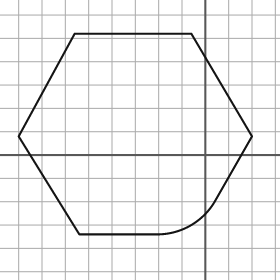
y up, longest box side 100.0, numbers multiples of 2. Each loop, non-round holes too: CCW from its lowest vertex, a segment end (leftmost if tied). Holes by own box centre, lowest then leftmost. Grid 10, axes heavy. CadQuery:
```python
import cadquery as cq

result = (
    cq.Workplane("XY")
    .moveTo(-54.0, -34.0)
    .lineTo(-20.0, -34.0)
    .threePointArc((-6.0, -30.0), (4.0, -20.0))
    .lineTo(20.0, 8.0)
    .lineTo(-6.0, 52.0)
    .lineTo(-56.0, 52.0)
    .lineTo(-80.0, 8.0)
    .close()
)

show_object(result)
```